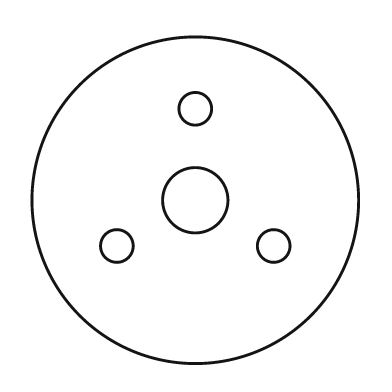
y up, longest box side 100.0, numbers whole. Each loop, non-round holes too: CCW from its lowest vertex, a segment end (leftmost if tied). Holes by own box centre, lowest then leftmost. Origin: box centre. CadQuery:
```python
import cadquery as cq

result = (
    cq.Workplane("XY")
    .moveTo(0.0, 0.0)
    .circle(50.0)
    .moveTo(-24.0, -14.0)
    .circle(5.0)
    .moveTo(24.0, -14.0)
    .circle(5.0)
    .moveTo(0.0, 0.0)
    .circle(10.0)
    .moveTo(0.0, 28.0)
    .circle(5.0)
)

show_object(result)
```